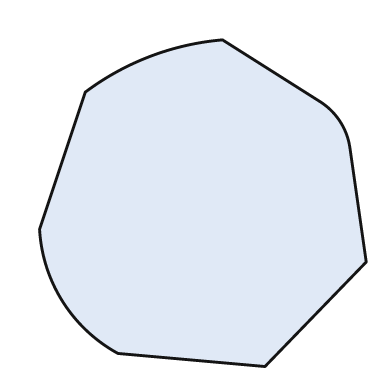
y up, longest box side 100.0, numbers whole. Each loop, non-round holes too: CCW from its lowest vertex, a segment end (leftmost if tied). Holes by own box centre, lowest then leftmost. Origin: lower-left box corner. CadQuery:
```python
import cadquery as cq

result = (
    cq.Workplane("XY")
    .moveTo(69.0, 0.0)
    .lineTo(100.0, 32.0)
    .lineTo(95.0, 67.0)
    .threePointArc((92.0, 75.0), (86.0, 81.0))
    .lineTo(56.0, 100.0)
    .threePointArc((34.0, 95.0), (14.0, 84.0))
    .lineTo(0.0, 42.0)
    .threePointArc((7.0, 20.0), (24.0, 4.0))
    .close()
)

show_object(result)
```